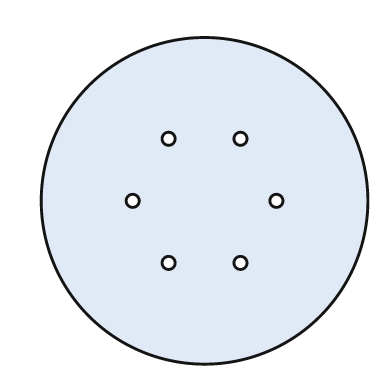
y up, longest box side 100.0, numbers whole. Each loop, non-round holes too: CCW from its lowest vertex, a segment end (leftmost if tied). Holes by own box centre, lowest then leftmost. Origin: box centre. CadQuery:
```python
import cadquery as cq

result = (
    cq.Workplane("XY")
    .moveTo(0.0, 0.0)
    .circle(50.0)
    .moveTo(-11.0, -19.0)
    .circle(2.0)
    .moveTo(11.0, -19.0)
    .circle(2.0)
    .moveTo(-22.0, 0.0)
    .circle(2.0)
    .moveTo(22.0, 0.0)
    .circle(2.0)
    .moveTo(-11.0, 19.0)
    .circle(2.0)
    .moveTo(11.0, 19.0)
    .circle(2.0)
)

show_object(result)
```